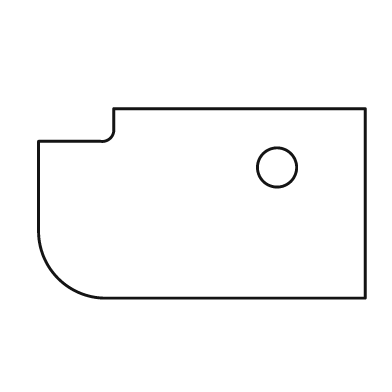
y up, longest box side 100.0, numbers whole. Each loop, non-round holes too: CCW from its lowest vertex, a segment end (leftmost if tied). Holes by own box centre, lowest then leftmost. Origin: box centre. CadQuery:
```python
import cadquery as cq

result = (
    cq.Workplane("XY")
    .moveTo(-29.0, -29.0)
    .lineTo(50.0, -29.0)
    .lineTo(50.0, 29.0)
    .lineTo(-27.0, 29.0)
    .lineTo(-27.0, 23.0)
    .threePointArc((-28.0, 20.0), (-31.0, 19.0))
    .lineTo(-50.0, 19.0)
    .lineTo(-50.0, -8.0)
    .threePointArc((-44.0, -23.0), (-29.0, -29.0))
    .close()
    .moveTo(23.0, 11.0)
    .circle(6.0)
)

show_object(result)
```